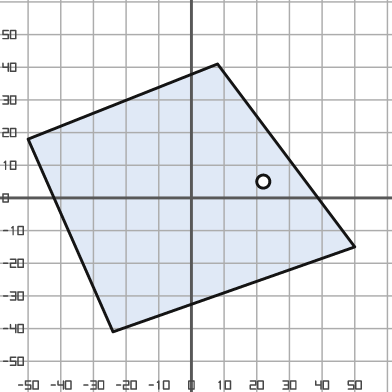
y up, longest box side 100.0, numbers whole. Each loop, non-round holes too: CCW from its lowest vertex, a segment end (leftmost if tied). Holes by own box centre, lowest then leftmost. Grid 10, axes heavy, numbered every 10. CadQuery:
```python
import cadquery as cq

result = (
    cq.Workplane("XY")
    .moveTo(-24.0, -41.0)
    .lineTo(50.0, -15.0)
    .lineTo(8.0, 41.0)
    .lineTo(-50.0, 18.0)
    .close()
    .moveTo(22.0, 5.0)
    .circle(2.0)
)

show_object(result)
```